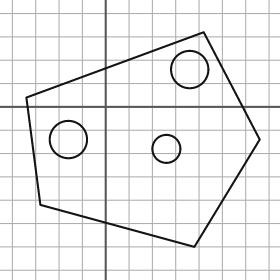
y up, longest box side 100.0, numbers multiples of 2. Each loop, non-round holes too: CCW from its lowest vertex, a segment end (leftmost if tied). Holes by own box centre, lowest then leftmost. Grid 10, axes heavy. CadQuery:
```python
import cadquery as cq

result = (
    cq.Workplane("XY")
    .moveTo(38.0, -60.0)
    .lineTo(66.0, -14.0)
    .lineTo(42.0, 32.0)
    .lineTo(-34.0, 4.0)
    .lineTo(-28.0, -42.0)
    .close()
    .moveTo(26.0, -18.0)
    .circle(6.0)
    .moveTo(-16.0, -14.0)
    .circle(8.0)
    .moveTo(36.0, 16.0)
    .circle(8.0)
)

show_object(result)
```